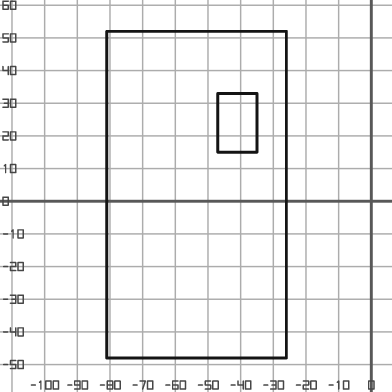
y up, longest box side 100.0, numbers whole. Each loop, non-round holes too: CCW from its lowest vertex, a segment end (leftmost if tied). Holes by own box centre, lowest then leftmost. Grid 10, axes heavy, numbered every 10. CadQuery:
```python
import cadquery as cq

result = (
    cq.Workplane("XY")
    .moveTo(-81.0, -48.0)
    .lineTo(-26.0, -48.0)
    .lineTo(-26.0, 52.0)
    .lineTo(-81.0, 52.0)
    .close()
    .moveTo(-47.0, 15.0)
    .lineTo(-35.0, 15.0)
    .lineTo(-35.0, 33.0)
    .lineTo(-47.0, 33.0)
    .close()
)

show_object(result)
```